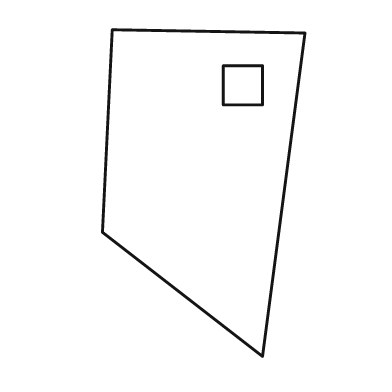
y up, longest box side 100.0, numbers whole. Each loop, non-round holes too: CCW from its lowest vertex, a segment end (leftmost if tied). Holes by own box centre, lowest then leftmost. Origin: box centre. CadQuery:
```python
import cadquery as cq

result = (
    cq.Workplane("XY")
    .moveTo(18.0, -50.0)
    .lineTo(31.0, 49.0)
    .lineTo(-28.0, 50.0)
    .lineTo(-31.0, -12.0)
    .close()
    .moveTo(6.0, 27.0)
    .lineTo(18.0, 27.0)
    .lineTo(18.0, 39.0)
    .lineTo(6.0, 39.0)
    .close()
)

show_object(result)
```